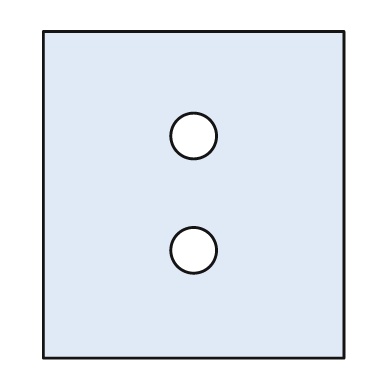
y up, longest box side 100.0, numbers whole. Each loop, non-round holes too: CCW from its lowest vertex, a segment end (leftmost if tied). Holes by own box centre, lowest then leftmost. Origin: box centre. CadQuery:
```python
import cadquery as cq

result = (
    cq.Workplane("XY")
    .moveTo(-46.0, -50.0)
    .lineTo(46.0, -50.0)
    .lineTo(46.0, 50.0)
    .lineTo(-46.0, 50.0)
    .close()
    .moveTo(0.0, -17.0)
    .circle(7.0)
    .moveTo(0.0, 18.0)
    .circle(7.0)
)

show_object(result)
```